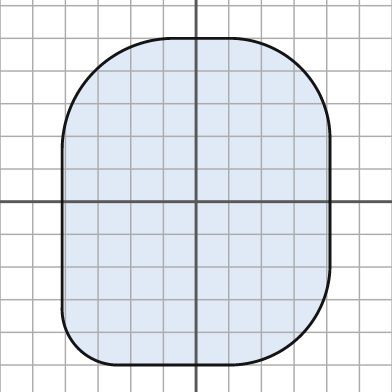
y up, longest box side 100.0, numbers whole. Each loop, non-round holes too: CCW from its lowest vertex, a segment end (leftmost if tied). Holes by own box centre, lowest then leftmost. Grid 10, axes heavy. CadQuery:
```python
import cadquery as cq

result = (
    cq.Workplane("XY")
    .moveTo(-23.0, -50.0)
    .lineTo(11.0, -50.0)
    .threePointArc((32.0, -41.0), (41.0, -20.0))
    .lineTo(41.0, 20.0)
    .threePointArc((32.0, 41.0), (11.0, 50.0))
    .lineTo(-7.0, 50.0)
    .threePointArc((-31.0, 40.0), (-41.0, 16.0))
    .lineTo(-41.0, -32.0)
    .threePointArc((-36.0, -45.0), (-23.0, -50.0))
    .close()
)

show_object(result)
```